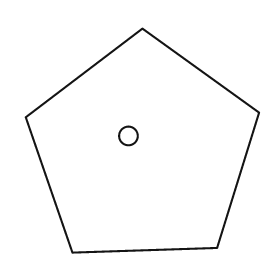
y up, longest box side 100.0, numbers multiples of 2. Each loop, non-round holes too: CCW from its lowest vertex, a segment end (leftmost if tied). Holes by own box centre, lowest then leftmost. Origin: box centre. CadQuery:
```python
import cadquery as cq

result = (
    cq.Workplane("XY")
    .moveTo(-30.0, -48.0)
    .lineTo(32.0, -46.0)
    .lineTo(50.0, 12.0)
    .lineTo(0.0, 48.0)
    .lineTo(-50.0, 10.0)
    .close()
    .moveTo(-6.0, 2.0)
    .circle(4.0)
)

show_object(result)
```